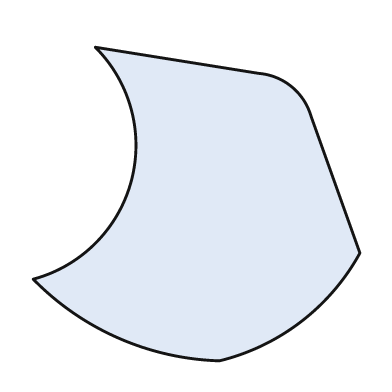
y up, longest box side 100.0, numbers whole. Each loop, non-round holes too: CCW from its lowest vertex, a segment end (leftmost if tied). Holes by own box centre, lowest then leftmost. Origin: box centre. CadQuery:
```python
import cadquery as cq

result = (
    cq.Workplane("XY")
    .moveTo(7.0, -48.0)
    .threePointArc((32.0, -36.0), (50.0, -15.0))
    .lineTo(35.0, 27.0)
    .threePointArc((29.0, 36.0), (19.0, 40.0))
    .lineTo(-31.0, 48.0)
    .threePointArc((-20.0, 7.0), (-50.0, -23.0))
    .threePointArc((-24.0, -41.0), (7.0, -48.0))
    .close()
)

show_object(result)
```